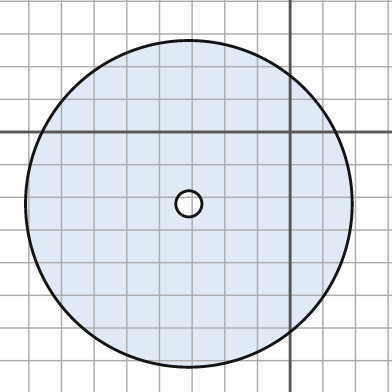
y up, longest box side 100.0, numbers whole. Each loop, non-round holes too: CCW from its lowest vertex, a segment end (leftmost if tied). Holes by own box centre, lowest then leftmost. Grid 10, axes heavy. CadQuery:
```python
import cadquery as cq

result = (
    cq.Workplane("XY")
    .moveTo(-31.0, -22.0)
    .circle(50.0)
    .moveTo(-31.0, -22.0)
    .circle(4.0)
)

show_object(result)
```